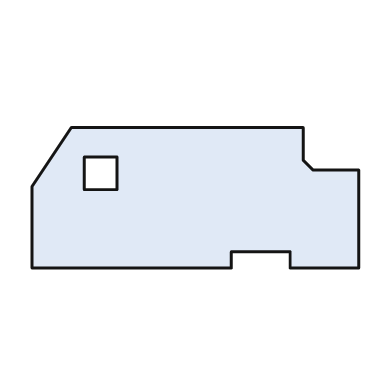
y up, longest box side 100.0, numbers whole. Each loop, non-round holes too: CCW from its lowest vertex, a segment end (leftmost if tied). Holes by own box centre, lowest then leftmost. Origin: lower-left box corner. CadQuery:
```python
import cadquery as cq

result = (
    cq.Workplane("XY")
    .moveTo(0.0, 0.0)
    .lineTo(61.0, 0.0)
    .lineTo(61.0, 5.0)
    .lineTo(79.0, 5.0)
    .lineTo(79.0, 0.0)
    .lineTo(100.0, 0.0)
    .lineTo(100.0, 30.0)
    .lineTo(86.0, 30.0)
    .lineTo(83.0, 33.0)
    .lineTo(83.0, 43.0)
    .lineTo(12.0, 43.0)
    .lineTo(0.0, 25.0)
    .close()
    .moveTo(16.0, 24.0)
    .lineTo(26.0, 24.0)
    .lineTo(26.0, 34.0)
    .lineTo(16.0, 34.0)
    .close()
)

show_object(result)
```